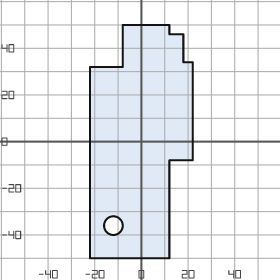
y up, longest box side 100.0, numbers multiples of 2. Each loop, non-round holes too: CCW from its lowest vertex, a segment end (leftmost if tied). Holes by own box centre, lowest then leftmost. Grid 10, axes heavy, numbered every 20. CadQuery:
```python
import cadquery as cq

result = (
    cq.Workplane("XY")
    .moveTo(-22.0, -50.0)
    .lineTo(12.0, -50.0)
    .lineTo(12.0, -8.0)
    .lineTo(22.0, -8.0)
    .lineTo(22.0, 34.0)
    .lineTo(18.0, 34.0)
    .lineTo(18.0, 46.0)
    .lineTo(12.0, 46.0)
    .lineTo(12.0, 50.0)
    .lineTo(-8.0, 50.0)
    .lineTo(-8.0, 32.0)
    .lineTo(-22.0, 32.0)
    .close()
    .moveTo(-12.0, -36.0)
    .circle(4.0)
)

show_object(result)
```